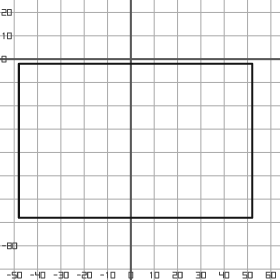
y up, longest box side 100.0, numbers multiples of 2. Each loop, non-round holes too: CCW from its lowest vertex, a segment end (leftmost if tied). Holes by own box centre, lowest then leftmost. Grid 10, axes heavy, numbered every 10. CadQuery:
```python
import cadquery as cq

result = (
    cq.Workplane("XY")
    .moveTo(-48.0, -68.0)
    .lineTo(52.0, -68.0)
    .lineTo(52.0, -2.0)
    .lineTo(-48.0, -2.0)
    .close()
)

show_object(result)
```